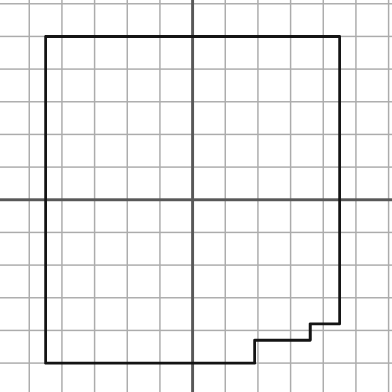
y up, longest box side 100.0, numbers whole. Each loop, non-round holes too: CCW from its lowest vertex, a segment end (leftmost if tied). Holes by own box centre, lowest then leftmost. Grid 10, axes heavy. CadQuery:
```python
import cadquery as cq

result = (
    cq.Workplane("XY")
    .moveTo(-45.0, -50.0)
    .lineTo(19.0, -50.0)
    .lineTo(19.0, -43.0)
    .lineTo(36.0, -43.0)
    .lineTo(36.0, -38.0)
    .lineTo(45.0, -38.0)
    .lineTo(45.0, 50.0)
    .lineTo(-45.0, 50.0)
    .close()
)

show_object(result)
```